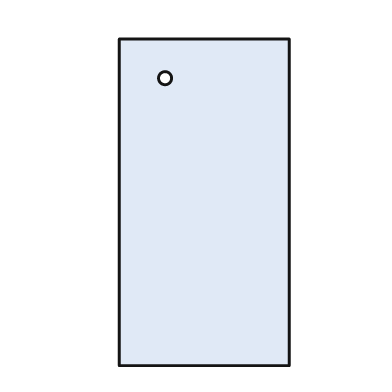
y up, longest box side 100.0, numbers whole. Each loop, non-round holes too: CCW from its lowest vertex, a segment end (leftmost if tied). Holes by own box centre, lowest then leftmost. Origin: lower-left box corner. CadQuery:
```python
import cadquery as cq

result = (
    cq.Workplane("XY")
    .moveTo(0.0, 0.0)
    .lineTo(52.0, 0.0)
    .lineTo(52.0, 100.0)
    .lineTo(0.0, 100.0)
    .close()
    .moveTo(14.0, 88.0)
    .circle(2.0)
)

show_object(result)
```